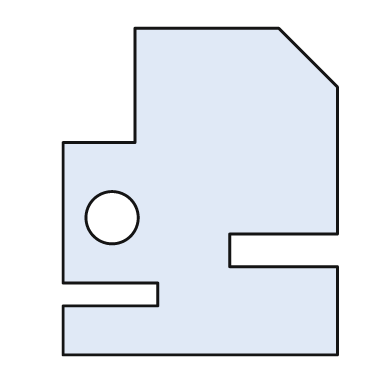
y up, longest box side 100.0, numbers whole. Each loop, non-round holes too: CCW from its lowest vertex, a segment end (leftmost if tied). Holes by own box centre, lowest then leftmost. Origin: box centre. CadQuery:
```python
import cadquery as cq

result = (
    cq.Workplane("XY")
    .moveTo(-42.0, -50.0)
    .lineTo(42.0, -50.0)
    .lineTo(42.0, -23.0)
    .lineTo(9.0, -23.0)
    .lineTo(9.0, -13.0)
    .lineTo(42.0, -13.0)
    .lineTo(42.0, 32.0)
    .lineTo(24.0, 50.0)
    .lineTo(-20.0, 50.0)
    .lineTo(-20.0, 15.0)
    .lineTo(-42.0, 15.0)
    .lineTo(-42.0, -28.0)
    .lineTo(-13.0, -28.0)
    .lineTo(-13.0, -35.0)
    .lineTo(-42.0, -35.0)
    .close()
    .moveTo(-27.0, -8.0)
    .circle(8.0)
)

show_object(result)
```